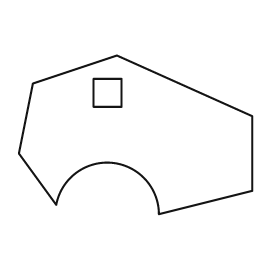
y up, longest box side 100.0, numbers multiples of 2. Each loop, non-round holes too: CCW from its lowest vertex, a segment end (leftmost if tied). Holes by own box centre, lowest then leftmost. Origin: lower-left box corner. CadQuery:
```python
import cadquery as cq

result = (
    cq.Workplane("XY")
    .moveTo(60.0, 0.0)
    .lineTo(100.0, 10.0)
    .lineTo(100.0, 42.0)
    .lineTo(42.0, 68.0)
    .lineTo(6.0, 56.0)
    .lineTo(0.0, 26.0)
    .lineTo(16.0, 4.0)
    .threePointArc((40.0, 22.0), (60.0, 0.0))
    .close()
    .moveTo(32.0, 46.0)
    .lineTo(44.0, 46.0)
    .lineTo(44.0, 58.0)
    .lineTo(32.0, 58.0)
    .close()
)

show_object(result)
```